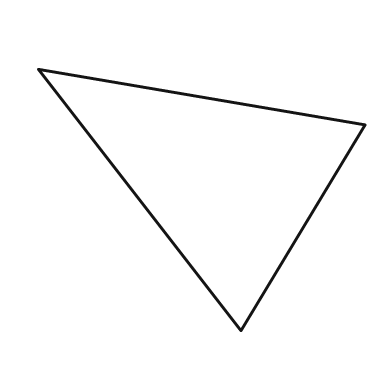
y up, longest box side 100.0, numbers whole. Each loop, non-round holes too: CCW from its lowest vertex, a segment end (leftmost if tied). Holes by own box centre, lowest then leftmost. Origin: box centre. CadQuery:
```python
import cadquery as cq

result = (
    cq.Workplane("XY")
    .moveTo(12.0, -40.0)
    .lineTo(50.0, 23.0)
    .lineTo(-50.0, 40.0)
    .close()
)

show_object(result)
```